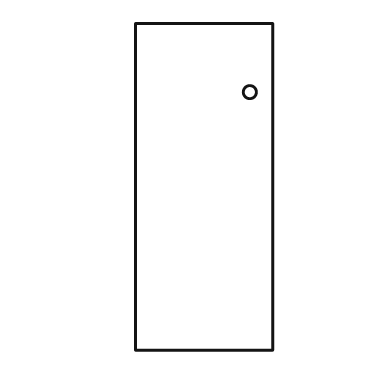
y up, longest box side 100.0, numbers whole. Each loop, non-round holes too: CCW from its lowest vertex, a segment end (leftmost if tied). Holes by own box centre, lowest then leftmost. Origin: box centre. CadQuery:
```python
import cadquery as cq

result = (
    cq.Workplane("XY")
    .moveTo(-21.0, -50.0)
    .lineTo(21.0, -50.0)
    .lineTo(21.0, 50.0)
    .lineTo(-21.0, 50.0)
    .close()
    .moveTo(14.0, 29.0)
    .circle(2.0)
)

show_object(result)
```